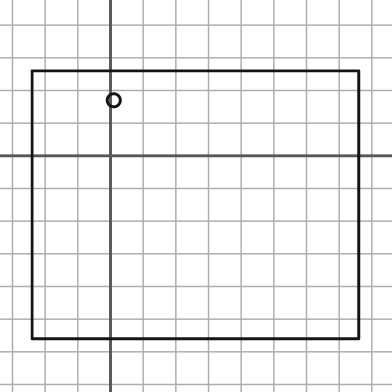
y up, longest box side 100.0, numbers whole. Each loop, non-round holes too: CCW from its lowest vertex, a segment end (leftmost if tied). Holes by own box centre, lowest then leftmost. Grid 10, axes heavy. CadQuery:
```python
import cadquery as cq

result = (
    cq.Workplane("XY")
    .moveTo(-24.0, -56.0)
    .lineTo(76.0, -56.0)
    .lineTo(76.0, 26.0)
    .lineTo(-24.0, 26.0)
    .close()
    .moveTo(1.0, 17.0)
    .circle(2.0)
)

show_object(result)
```